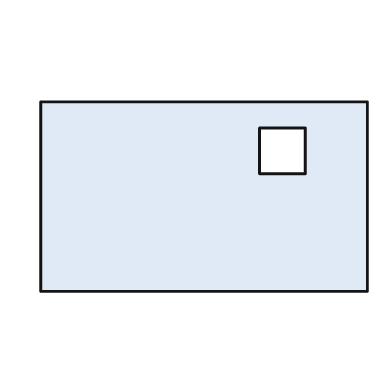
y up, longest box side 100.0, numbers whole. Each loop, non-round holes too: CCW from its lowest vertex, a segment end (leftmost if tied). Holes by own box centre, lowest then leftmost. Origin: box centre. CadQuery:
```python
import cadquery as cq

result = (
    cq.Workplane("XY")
    .moveTo(-50.0, -29.0)
    .lineTo(50.0, -29.0)
    .lineTo(50.0, 29.0)
    .lineTo(-50.0, 29.0)
    .close()
    .moveTo(17.0, 7.0)
    .lineTo(31.0, 7.0)
    .lineTo(31.0, 21.0)
    .lineTo(17.0, 21.0)
    .close()
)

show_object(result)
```